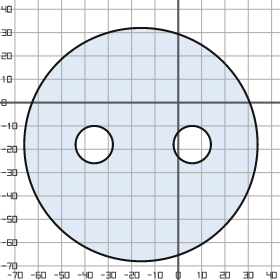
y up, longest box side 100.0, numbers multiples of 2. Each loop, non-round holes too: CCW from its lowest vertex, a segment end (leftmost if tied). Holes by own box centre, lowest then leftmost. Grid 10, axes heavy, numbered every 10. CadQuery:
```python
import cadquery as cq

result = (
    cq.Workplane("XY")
    .moveTo(-16.0, -18.0)
    .circle(50.0)
    .moveTo(-36.0, -18.0)
    .circle(8.0)
    .moveTo(6.0, -18.0)
    .circle(8.0)
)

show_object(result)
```